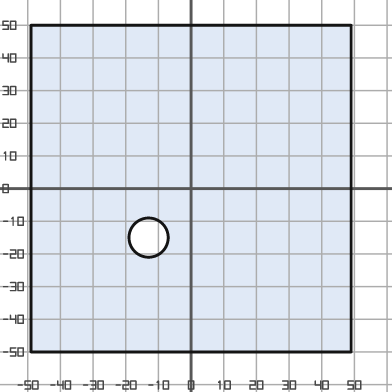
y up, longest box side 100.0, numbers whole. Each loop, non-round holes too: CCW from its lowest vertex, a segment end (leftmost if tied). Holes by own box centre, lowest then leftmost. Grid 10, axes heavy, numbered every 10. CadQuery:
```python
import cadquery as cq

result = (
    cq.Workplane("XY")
    .moveTo(-49.0, -50.0)
    .lineTo(49.0, -50.0)
    .lineTo(49.0, 50.0)
    .lineTo(-49.0, 50.0)
    .close()
    .moveTo(-13.0, -15.0)
    .circle(6.0)
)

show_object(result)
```